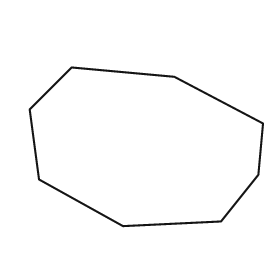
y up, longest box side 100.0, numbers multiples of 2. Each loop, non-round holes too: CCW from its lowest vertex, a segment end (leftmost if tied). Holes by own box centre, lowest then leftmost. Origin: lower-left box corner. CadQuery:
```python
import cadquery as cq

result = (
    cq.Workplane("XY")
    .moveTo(40.0, 0.0)
    .lineTo(82.0, 2.0)
    .lineTo(98.0, 22.0)
    .lineTo(100.0, 44.0)
    .lineTo(62.0, 64.0)
    .lineTo(18.0, 68.0)
    .lineTo(0.0, 50.0)
    .lineTo(4.0, 20.0)
    .close()
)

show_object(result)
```